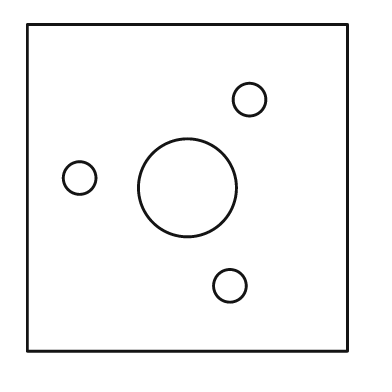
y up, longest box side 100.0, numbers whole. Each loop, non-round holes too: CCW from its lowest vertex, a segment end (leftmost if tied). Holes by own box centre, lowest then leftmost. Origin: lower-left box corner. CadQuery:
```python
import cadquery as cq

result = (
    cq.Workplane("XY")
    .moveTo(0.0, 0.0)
    .lineTo(98.0, 0.0)
    .lineTo(98.0, 100.0)
    .lineTo(0.0, 100.0)
    .close()
    .moveTo(62.0, 20.0)
    .circle(5.0)
    .moveTo(49.0, 50.0)
    .circle(15.0)
    .moveTo(16.0, 53.0)
    .circle(5.0)
    .moveTo(68.0, 77.0)
    .circle(5.0)
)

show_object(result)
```